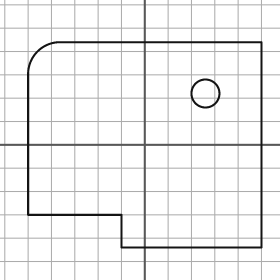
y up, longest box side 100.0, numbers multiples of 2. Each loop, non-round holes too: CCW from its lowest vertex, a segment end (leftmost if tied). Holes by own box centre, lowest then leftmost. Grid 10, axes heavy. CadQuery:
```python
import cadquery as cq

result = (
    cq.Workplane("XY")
    .moveTo(-10.0, -44.0)
    .lineTo(50.0, -44.0)
    .lineTo(50.0, 44.0)
    .lineTo(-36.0, 44.0)
    .threePointArc((-46.0, 40.0), (-50.0, 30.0))
    .lineTo(-50.0, -30.0)
    .lineTo(-10.0, -30.0)
    .close()
    .moveTo(26.0, 22.0)
    .circle(6.0)
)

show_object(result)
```